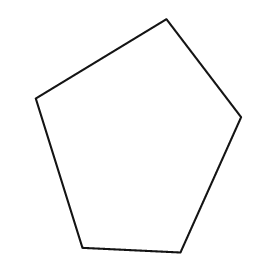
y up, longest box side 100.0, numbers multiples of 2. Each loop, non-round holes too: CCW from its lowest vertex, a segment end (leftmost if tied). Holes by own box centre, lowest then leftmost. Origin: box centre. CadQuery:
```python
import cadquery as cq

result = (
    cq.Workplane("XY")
    .moveTo(18.0, -50.0)
    .lineTo(44.0, 8.0)
    .lineTo(12.0, 50.0)
    .lineTo(-44.0, 16.0)
    .lineTo(-24.0, -48.0)
    .close()
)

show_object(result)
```